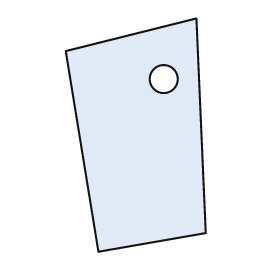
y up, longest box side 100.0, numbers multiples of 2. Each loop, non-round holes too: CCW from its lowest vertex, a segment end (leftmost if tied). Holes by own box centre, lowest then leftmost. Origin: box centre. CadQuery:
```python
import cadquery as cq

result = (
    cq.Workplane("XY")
    .moveTo(-16.0, -50.0)
    .lineTo(30.0, -42.0)
    .lineTo(26.0, 50.0)
    .lineTo(-30.0, 36.0)
    .close()
    .moveTo(12.0, 24.0)
    .circle(6.0)
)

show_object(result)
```